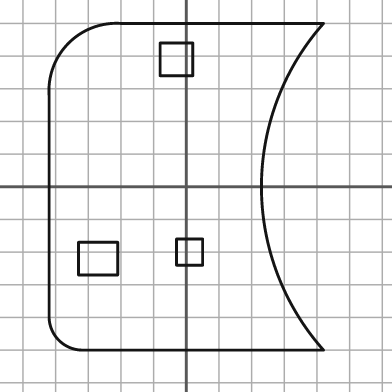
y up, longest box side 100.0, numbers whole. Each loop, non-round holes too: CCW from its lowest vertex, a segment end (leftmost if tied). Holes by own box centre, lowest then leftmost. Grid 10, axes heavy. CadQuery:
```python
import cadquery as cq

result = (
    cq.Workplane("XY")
    .moveTo(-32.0, -50.0)
    .lineTo(42.0, -50.0)
    .threePointArc((23.0, 0.0), (42.0, 50.0))
    .lineTo(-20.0, 50.0)
    .threePointArc((-36.0, 44.0), (-42.0, 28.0))
    .lineTo(-42.0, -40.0)
    .threePointArc((-39.0, -47.0), (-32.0, -50.0))
    .close()
    .moveTo(-33.0, -27.0)
    .lineTo(-21.0, -27.0)
    .lineTo(-21.0, -17.0)
    .lineTo(-33.0, -17.0)
    .close()
    .moveTo(-3.0, -24.0)
    .lineTo(5.0, -24.0)
    .lineTo(5.0, -16.0)
    .lineTo(-3.0, -16.0)
    .close()
    .moveTo(-8.0, 34.0)
    .lineTo(2.0, 34.0)
    .lineTo(2.0, 44.0)
    .lineTo(-8.0, 44.0)
    .close()
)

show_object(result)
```